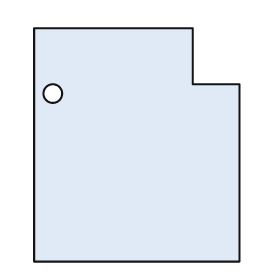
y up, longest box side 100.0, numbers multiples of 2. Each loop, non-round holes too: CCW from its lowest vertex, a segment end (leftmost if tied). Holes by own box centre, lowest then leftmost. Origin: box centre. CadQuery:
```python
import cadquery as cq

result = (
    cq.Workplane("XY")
    .moveTo(-44.0, -50.0)
    .lineTo(44.0, -50.0)
    .lineTo(44.0, 26.0)
    .lineTo(24.0, 26.0)
    .lineTo(24.0, 50.0)
    .lineTo(-44.0, 50.0)
    .close()
    .moveTo(-36.0, 22.0)
    .circle(4.0)
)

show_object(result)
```